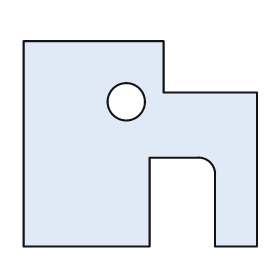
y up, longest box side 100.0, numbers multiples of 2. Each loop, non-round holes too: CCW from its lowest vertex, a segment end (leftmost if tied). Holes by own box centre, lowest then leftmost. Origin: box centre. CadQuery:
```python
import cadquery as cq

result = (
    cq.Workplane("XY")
    .moveTo(-50.0, -44.0)
    .lineTo(4.0, -44.0)
    .lineTo(4.0, -6.0)
    .lineTo(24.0, -6.0)
    .threePointArc((30.0, -8.0), (32.0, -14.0))
    .lineTo(32.0, -44.0)
    .lineTo(50.0, -44.0)
    .lineTo(50.0, 22.0)
    .lineTo(10.0, 22.0)
    .lineTo(10.0, 44.0)
    .lineTo(-50.0, 44.0)
    .close()
    .moveTo(-6.0, 18.0)
    .circle(8.0)
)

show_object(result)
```